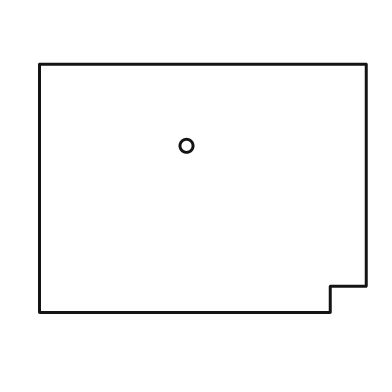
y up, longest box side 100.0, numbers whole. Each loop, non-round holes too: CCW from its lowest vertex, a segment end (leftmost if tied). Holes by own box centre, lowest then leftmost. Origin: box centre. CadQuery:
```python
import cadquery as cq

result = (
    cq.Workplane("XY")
    .moveTo(-50.0, -38.0)
    .lineTo(39.0, -38.0)
    .lineTo(39.0, -30.0)
    .lineTo(50.0, -30.0)
    .lineTo(50.0, 38.0)
    .lineTo(-50.0, 38.0)
    .close()
    .moveTo(-5.0, 13.0)
    .circle(2.0)
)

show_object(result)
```